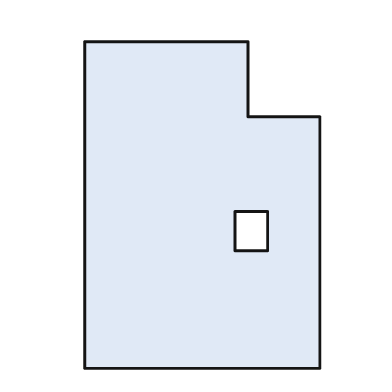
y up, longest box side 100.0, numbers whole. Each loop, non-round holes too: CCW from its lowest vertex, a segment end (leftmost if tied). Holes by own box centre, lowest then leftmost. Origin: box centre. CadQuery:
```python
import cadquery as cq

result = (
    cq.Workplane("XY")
    .moveTo(-36.0, -50.0)
    .lineTo(36.0, -50.0)
    .lineTo(36.0, 27.0)
    .lineTo(14.0, 27.0)
    .lineTo(14.0, 50.0)
    .lineTo(-36.0, 50.0)
    .close()
    .moveTo(10.0, -14.0)
    .lineTo(20.0, -14.0)
    .lineTo(20.0, -2.0)
    .lineTo(10.0, -2.0)
    .close()
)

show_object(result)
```